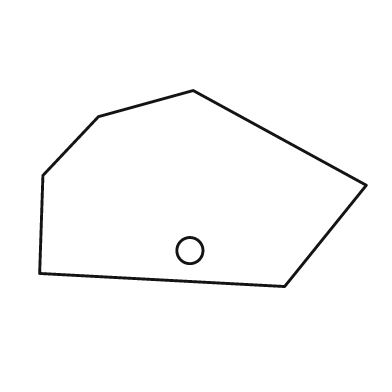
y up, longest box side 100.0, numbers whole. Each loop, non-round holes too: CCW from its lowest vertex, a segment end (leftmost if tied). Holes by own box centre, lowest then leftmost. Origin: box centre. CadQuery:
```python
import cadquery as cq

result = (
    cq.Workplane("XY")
    .moveTo(25.0, -30.0)
    .lineTo(50.0, 1.0)
    .lineTo(-3.0, 30.0)
    .lineTo(-32.0, 22.0)
    .lineTo(-49.0, 4.0)
    .lineTo(-50.0, -26.0)
    .close()
    .moveTo(-4.0, -19.0)
    .circle(4.0)
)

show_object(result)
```